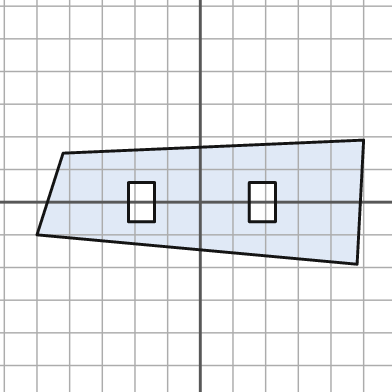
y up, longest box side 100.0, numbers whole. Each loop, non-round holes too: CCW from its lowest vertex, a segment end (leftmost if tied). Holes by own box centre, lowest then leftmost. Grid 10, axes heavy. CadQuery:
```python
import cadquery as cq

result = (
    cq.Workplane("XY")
    .moveTo(48.0, -19.0)
    .lineTo(50.0, 19.0)
    .lineTo(-42.0, 15.0)
    .lineTo(-50.0, -10.0)
    .close()
    .moveTo(-22.0, -6.0)
    .lineTo(-14.0, -6.0)
    .lineTo(-14.0, 6.0)
    .lineTo(-22.0, 6.0)
    .close()
    .moveTo(15.0, -6.0)
    .lineTo(23.0, -6.0)
    .lineTo(23.0, 6.0)
    .lineTo(15.0, 6.0)
    .close()
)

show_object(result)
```